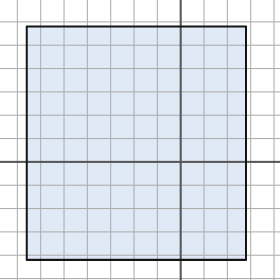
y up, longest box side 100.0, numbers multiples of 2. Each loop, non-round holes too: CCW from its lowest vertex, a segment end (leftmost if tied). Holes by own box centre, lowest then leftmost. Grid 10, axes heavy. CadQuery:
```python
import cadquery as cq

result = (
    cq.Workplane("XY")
    .moveTo(-66.0, -42.0)
    .lineTo(28.0, -42.0)
    .lineTo(28.0, 58.0)
    .lineTo(-66.0, 58.0)
    .close()
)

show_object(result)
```